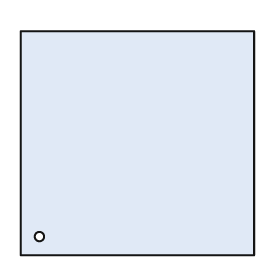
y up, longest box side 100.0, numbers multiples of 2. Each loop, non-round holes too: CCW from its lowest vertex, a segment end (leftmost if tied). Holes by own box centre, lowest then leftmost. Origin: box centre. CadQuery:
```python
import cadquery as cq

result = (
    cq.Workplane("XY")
    .moveTo(-50.0, -48.0)
    .lineTo(50.0, -48.0)
    .lineTo(50.0, 48.0)
    .lineTo(-50.0, 48.0)
    .close()
    .moveTo(-42.0, -40.0)
    .circle(2.0)
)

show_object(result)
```